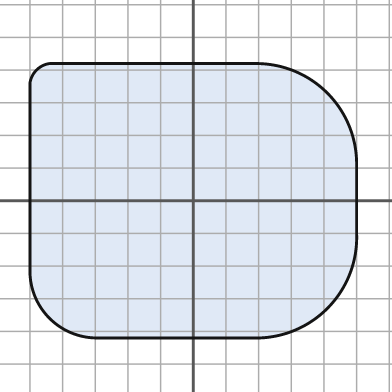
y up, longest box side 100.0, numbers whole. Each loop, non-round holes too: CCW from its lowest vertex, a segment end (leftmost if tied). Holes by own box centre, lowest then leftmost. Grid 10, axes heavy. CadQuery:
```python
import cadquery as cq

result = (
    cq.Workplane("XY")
    .moveTo(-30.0, -42.0)
    .lineTo(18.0, -42.0)
    .threePointArc((41.0, -33.0), (50.0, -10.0))
    .lineTo(50.0, 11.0)
    .threePointArc((41.0, 33.0), (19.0, 42.0))
    .lineTo(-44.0, 42.0)
    .threePointArc((-48.0, 40.0), (-50.0, 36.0))
    .lineTo(-50.0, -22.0)
    .threePointArc((-44.0, -36.0), (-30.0, -42.0))
    .close()
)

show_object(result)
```